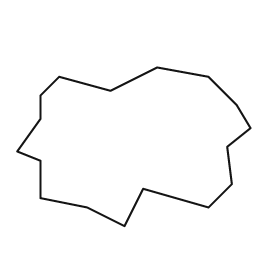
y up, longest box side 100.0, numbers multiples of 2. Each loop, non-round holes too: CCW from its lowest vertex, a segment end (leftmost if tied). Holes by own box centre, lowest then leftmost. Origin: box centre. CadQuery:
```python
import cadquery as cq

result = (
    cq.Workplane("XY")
    .moveTo(-4.0, -34.0)
    .lineTo(4.0, -18.0)
    .lineTo(32.0, -26.0)
    .lineTo(42.0, -16.0)
    .lineTo(40.0, 0.0)
    .lineTo(50.0, 8.0)
    .lineTo(44.0, 18.0)
    .lineTo(32.0, 30.0)
    .lineTo(10.0, 34.0)
    .lineTo(-10.0, 24.0)
    .lineTo(-32.0, 30.0)
    .lineTo(-40.0, 22.0)
    .lineTo(-40.0, 12.0)
    .lineTo(-50.0, -2.0)
    .lineTo(-40.0, -6.0)
    .lineTo(-40.0, -22.0)
    .lineTo(-20.0, -26.0)
    .close()
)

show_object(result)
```